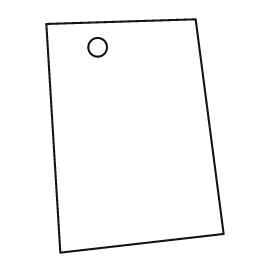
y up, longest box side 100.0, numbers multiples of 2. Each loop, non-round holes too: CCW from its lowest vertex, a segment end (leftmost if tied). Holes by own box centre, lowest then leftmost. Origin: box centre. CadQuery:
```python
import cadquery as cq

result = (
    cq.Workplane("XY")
    .moveTo(-32.0, -50.0)
    .lineTo(38.0, -42.0)
    .lineTo(26.0, 50.0)
    .lineTo(-38.0, 48.0)
    .close()
    .moveTo(-16.0, 38.0)
    .circle(4.0)
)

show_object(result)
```